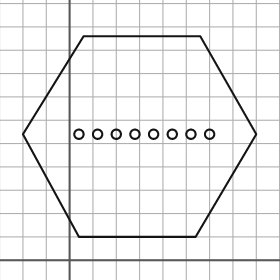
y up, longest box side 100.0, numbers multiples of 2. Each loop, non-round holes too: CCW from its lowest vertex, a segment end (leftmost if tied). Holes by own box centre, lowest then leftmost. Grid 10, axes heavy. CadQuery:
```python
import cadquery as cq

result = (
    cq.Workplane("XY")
    .moveTo(4.0, 10.0)
    .lineTo(54.0, 10.0)
    .lineTo(80.0, 54.0)
    .lineTo(56.0, 96.0)
    .lineTo(6.0, 96.0)
    .lineTo(-20.0, 54.0)
    .close()
    .moveTo(4.0, 54.0)
    .circle(2.0)
    .moveTo(12.0, 54.0)
    .circle(2.0)
    .moveTo(20.0, 54.0)
    .circle(2.0)
    .moveTo(28.0, 54.0)
    .circle(2.0)
    .moveTo(36.0, 54.0)
    .circle(2.0)
    .moveTo(44.0, 54.0)
    .circle(2.0)
    .moveTo(52.0, 54.0)
    .circle(2.0)
    .moveTo(60.0, 54.0)
    .circle(2.0)
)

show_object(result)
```